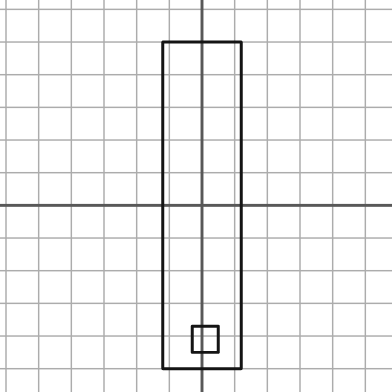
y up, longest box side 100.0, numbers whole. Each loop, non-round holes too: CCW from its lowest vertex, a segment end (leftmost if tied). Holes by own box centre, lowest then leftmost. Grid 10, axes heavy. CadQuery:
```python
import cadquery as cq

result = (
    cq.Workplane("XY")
    .moveTo(-12.0, -50.0)
    .lineTo(12.0, -50.0)
    .lineTo(12.0, 50.0)
    .lineTo(-12.0, 50.0)
    .close()
    .moveTo(-3.0, -45.0)
    .lineTo(5.0, -45.0)
    .lineTo(5.0, -37.0)
    .lineTo(-3.0, -37.0)
    .close()
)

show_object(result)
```